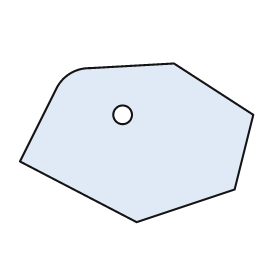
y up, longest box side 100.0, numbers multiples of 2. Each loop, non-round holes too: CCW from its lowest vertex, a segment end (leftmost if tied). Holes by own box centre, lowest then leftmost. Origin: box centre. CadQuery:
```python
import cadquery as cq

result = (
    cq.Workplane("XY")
    .moveTo(0.0, -34.0)
    .lineTo(42.0, -20.0)
    .lineTo(50.0, 12.0)
    .lineTo(16.0, 34.0)
    .lineTo(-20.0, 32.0)
    .threePointArc((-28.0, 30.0), (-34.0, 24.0))
    .lineTo(-50.0, -8.0)
    .close()
    .moveTo(-6.0, 12.0)
    .circle(4.0)
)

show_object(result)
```